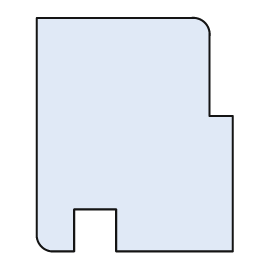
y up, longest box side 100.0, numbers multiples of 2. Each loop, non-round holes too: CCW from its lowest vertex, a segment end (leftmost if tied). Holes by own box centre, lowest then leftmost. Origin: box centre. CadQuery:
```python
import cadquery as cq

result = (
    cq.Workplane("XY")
    .moveTo(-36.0, -50.0)
    .lineTo(-26.0, -50.0)
    .lineTo(-26.0, -32.0)
    .lineTo(-8.0, -32.0)
    .lineTo(-8.0, -50.0)
    .lineTo(42.0, -50.0)
    .lineTo(42.0, 8.0)
    .lineTo(32.0, 8.0)
    .lineTo(32.0, 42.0)
    .threePointArc((30.0, 48.0), (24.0, 50.0))
    .lineTo(-42.0, 50.0)
    .lineTo(-42.0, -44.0)
    .threePointArc((-40.0, -48.0), (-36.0, -50.0))
    .close()
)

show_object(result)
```